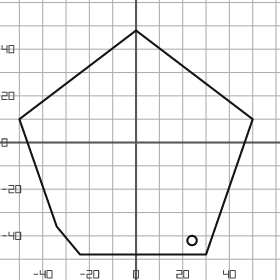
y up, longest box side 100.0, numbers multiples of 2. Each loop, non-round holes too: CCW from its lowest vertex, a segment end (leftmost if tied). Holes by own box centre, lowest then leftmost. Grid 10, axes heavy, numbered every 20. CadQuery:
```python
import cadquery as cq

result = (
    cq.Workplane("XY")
    .moveTo(-24.0, -48.0)
    .lineTo(30.0, -48.0)
    .lineTo(50.0, 10.0)
    .lineTo(0.0, 48.0)
    .lineTo(-50.0, 10.0)
    .lineTo(-34.0, -36.0)
    .close()
    .moveTo(24.0, -42.0)
    .circle(2.0)
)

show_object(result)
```